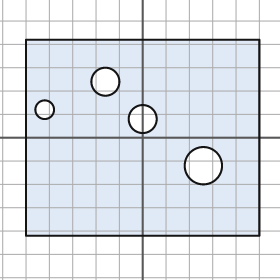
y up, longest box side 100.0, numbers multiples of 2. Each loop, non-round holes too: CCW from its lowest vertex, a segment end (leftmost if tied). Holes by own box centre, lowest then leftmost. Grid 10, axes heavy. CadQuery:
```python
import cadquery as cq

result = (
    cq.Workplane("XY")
    .moveTo(-50.0, -42.0)
    .lineTo(50.0, -42.0)
    .lineTo(50.0, 42.0)
    .lineTo(-50.0, 42.0)
    .close()
    .moveTo(26.0, -12.0)
    .circle(8.0)
    .moveTo(0.0, 8.0)
    .circle(6.0)
    .moveTo(-42.0, 12.0)
    .circle(4.0)
    .moveTo(-16.0, 24.0)
    .circle(6.0)
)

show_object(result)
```